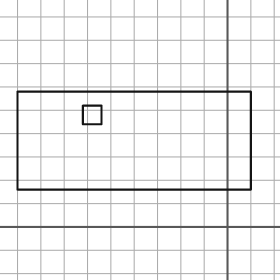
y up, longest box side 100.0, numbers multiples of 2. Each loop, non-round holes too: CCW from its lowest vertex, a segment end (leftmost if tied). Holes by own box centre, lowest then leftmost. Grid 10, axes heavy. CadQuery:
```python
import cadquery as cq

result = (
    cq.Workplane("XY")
    .moveTo(-90.0, 16.0)
    .lineTo(10.0, 16.0)
    .lineTo(10.0, 58.0)
    .lineTo(-90.0, 58.0)
    .close()
    .moveTo(-62.0, 44.0)
    .lineTo(-54.0, 44.0)
    .lineTo(-54.0, 52.0)
    .lineTo(-62.0, 52.0)
    .close()
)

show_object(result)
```